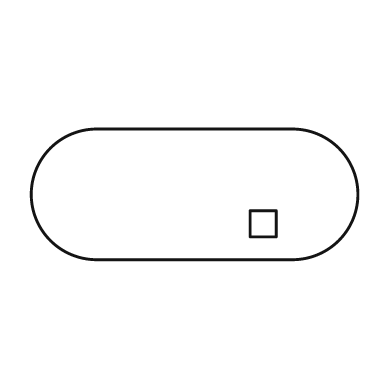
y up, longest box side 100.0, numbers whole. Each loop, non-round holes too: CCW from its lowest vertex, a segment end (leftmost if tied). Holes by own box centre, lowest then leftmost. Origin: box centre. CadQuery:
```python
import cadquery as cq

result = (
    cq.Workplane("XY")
    .moveTo(-30.0, -20.0)
    .lineTo(30.0, -20.0)
    .threePointArc((50.0, 0.0), (30.0, 20.0))
    .lineTo(-30.0, 20.0)
    .threePointArc((-50.0, 0.0), (-30.0, -20.0))
    .close()
    .moveTo(17.0, -13.0)
    .lineTo(25.0, -13.0)
    .lineTo(25.0, -5.0)
    .lineTo(17.0, -5.0)
    .close()
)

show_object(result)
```